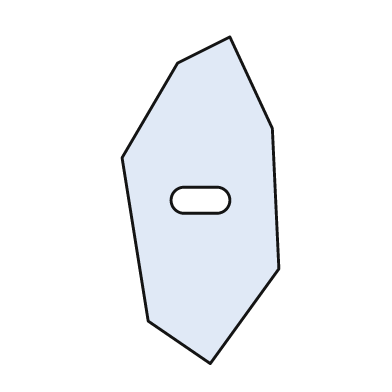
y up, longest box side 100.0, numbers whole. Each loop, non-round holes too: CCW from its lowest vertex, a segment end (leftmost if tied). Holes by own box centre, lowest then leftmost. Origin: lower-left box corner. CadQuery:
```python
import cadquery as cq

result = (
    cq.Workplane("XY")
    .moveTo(27.0, 0.0)
    .lineTo(48.0, 29.0)
    .lineTo(46.0, 72.0)
    .lineTo(33.0, 100.0)
    .lineTo(17.0, 92.0)
    .lineTo(0.0, 63.0)
    .lineTo(8.0, 13.0)
    .close()
    .moveTo(19.0, 46.0)
    .lineTo(29.0, 46.0)
    .threePointArc((33.0, 50.0), (29.0, 54.0))
    .lineTo(19.0, 54.0)
    .threePointArc((15.0, 50.0), (19.0, 46.0))
    .close()
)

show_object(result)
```